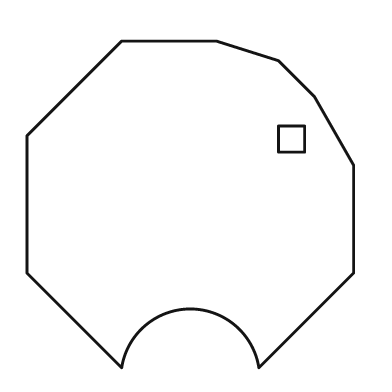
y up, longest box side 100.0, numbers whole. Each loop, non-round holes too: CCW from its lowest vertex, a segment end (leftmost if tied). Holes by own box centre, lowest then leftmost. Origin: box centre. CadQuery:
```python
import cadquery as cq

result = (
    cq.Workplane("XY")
    .moveTo(-21.0, -50.0)
    .threePointArc((0.0, -32.0), (21.0, -50.0))
    .lineTo(50.0, -21.0)
    .lineTo(50.0, 12.0)
    .lineTo(38.0, 33.0)
    .lineTo(27.0, 44.0)
    .lineTo(8.0, 50.0)
    .lineTo(-21.0, 50.0)
    .lineTo(-50.0, 21.0)
    .lineTo(-50.0, -21.0)
    .close()
    .moveTo(27.0, 16.0)
    .lineTo(35.0, 16.0)
    .lineTo(35.0, 24.0)
    .lineTo(27.0, 24.0)
    .close()
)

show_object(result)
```